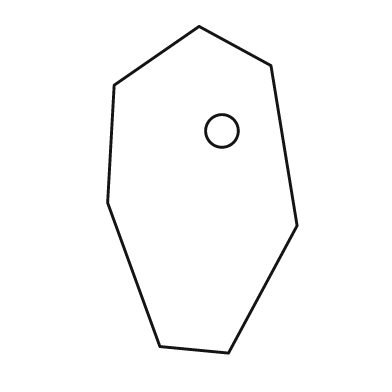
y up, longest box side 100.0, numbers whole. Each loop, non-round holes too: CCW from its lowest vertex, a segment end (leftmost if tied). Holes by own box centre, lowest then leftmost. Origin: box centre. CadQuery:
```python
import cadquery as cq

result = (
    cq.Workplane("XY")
    .moveTo(8.0, -50.0)
    .lineTo(29.0, -11.0)
    .lineTo(21.0, 38.0)
    .lineTo(-1.0, 50.0)
    .lineTo(-27.0, 32.0)
    .lineTo(-29.0, -4.0)
    .lineTo(-13.0, -48.0)
    .close()
    .moveTo(6.0, 18.0)
    .circle(5.0)
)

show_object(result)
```